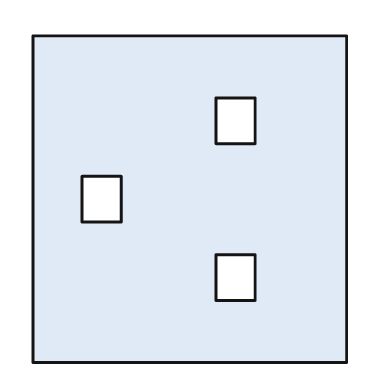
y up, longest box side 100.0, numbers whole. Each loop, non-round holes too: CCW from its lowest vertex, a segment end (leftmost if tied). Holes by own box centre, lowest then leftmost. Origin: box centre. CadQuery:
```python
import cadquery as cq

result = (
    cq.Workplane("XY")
    .moveTo(-48.0, -50.0)
    .lineTo(48.0, -50.0)
    .lineTo(48.0, 50.0)
    .lineTo(-48.0, 50.0)
    .close()
    .moveTo(8.0, -31.0)
    .lineTo(20.0, -31.0)
    .lineTo(20.0, -17.0)
    .lineTo(8.0, -17.0)
    .close()
    .moveTo(-33.0, -7.0)
    .lineTo(-21.0, -7.0)
    .lineTo(-21.0, 7.0)
    .lineTo(-33.0, 7.0)
    .close()
    .moveTo(8.0, 17.0)
    .lineTo(20.0, 17.0)
    .lineTo(20.0, 31.0)
    .lineTo(8.0, 31.0)
    .close()
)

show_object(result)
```